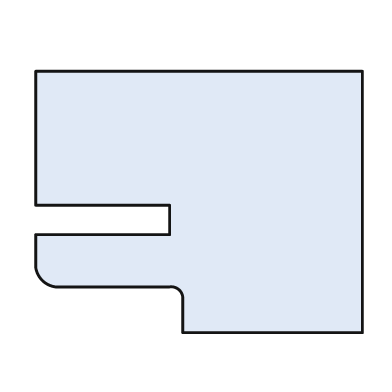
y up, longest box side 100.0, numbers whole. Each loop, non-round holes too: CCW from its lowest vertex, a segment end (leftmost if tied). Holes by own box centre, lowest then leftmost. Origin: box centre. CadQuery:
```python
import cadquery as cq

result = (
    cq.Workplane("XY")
    .moveTo(-5.0, -40.0)
    .lineTo(50.0, -40.0)
    .lineTo(50.0, 40.0)
    .lineTo(-50.0, 40.0)
    .lineTo(-50.0, -1.0)
    .lineTo(-9.0, -1.0)
    .lineTo(-9.0, -10.0)
    .lineTo(-50.0, -10.0)
    .lineTo(-50.0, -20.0)
    .threePointArc((-48.0, -24.0), (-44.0, -26.0))
    .lineTo(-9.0, -26.0)
    .threePointArc((-6.0, -27.0), (-5.0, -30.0))
    .close()
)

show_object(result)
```